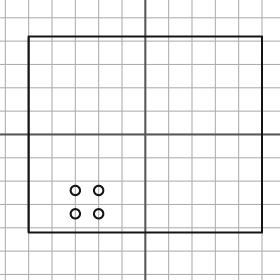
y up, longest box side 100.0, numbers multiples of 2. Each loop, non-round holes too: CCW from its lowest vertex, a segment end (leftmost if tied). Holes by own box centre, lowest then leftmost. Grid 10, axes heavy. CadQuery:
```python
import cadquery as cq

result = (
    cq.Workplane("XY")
    .moveTo(-50.0, -42.0)
    .lineTo(50.0, -42.0)
    .lineTo(50.0, 42.0)
    .lineTo(-50.0, 42.0)
    .close()
    .moveTo(-30.0, -34.0)
    .circle(2.0)
    .moveTo(-20.0, -34.0)
    .circle(2.0)
    .moveTo(-30.0, -24.0)
    .circle(2.0)
    .moveTo(-20.0, -24.0)
    .circle(2.0)
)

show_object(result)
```